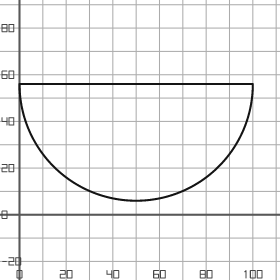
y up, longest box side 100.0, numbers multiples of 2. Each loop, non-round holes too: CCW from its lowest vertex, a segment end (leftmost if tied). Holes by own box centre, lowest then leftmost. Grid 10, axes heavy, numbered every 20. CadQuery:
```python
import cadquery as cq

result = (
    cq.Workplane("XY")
    .moveTo(0.0, 56.0)
    .threePointArc((50.0, 6.0), (100.0, 56.0))
    .close()
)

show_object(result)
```